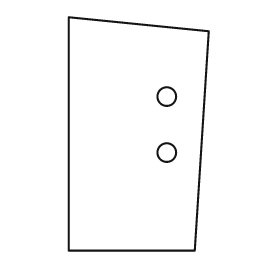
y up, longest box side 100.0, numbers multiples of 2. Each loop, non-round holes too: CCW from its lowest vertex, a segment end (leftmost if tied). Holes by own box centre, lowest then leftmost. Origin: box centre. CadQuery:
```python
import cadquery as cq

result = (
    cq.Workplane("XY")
    .moveTo(-30.0, -50.0)
    .lineTo(24.0, -50.0)
    .lineTo(30.0, 44.0)
    .lineTo(-30.0, 50.0)
    .close()
    .moveTo(12.0, -8.0)
    .circle(4.0)
    .moveTo(12.0, 16.0)
    .circle(4.0)
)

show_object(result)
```